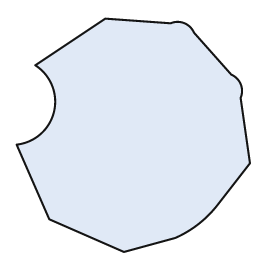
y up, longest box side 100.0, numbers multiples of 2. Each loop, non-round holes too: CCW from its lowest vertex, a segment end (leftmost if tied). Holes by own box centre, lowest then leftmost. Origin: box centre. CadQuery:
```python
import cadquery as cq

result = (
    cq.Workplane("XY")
    .moveTo(-4.0, -50.0)
    .lineTo(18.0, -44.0)
    .threePointArc((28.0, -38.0), (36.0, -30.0))
    .lineTo(50.0, -12.0)
    .lineTo(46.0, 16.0)
    .threePointArc((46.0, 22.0), (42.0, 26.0))
    .lineTo(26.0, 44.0)
    .threePointArc((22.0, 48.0), (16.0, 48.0))
    .lineTo(-12.0, 50.0)
    .lineTo(-42.0, 30.0)
    .threePointArc((-34.0, 10.0), (-50.0, -4.0))
    .lineTo(-36.0, -36.0)
    .close()
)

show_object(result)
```